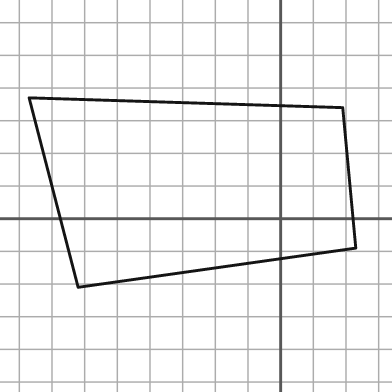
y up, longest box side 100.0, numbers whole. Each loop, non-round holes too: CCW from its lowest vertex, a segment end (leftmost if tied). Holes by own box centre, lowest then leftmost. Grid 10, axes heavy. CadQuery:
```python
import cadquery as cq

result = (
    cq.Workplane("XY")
    .moveTo(-62.0, -21.0)
    .lineTo(23.0, -9.0)
    .lineTo(19.0, 34.0)
    .lineTo(-77.0, 37.0)
    .close()
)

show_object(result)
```